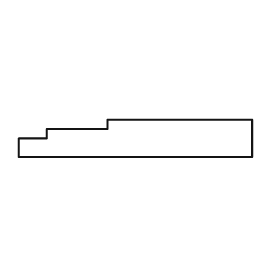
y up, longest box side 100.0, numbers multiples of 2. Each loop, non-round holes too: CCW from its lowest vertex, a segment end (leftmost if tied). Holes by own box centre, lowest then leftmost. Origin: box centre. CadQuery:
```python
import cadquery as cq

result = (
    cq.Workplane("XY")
    .moveTo(-50.0, -8.0)
    .lineTo(50.0, -8.0)
    .lineTo(50.0, 8.0)
    .lineTo(-12.0, 8.0)
    .lineTo(-12.0, 4.0)
    .lineTo(-38.0, 4.0)
    .lineTo(-38.0, 0.0)
    .lineTo(-50.0, 0.0)
    .close()
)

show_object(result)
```